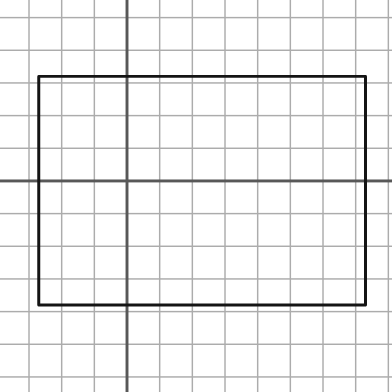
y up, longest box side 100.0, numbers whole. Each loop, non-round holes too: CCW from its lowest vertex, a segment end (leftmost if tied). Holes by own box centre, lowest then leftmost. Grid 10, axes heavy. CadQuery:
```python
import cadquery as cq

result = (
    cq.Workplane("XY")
    .moveTo(-27.0, -38.0)
    .lineTo(73.0, -38.0)
    .lineTo(73.0, 32.0)
    .lineTo(-27.0, 32.0)
    .close()
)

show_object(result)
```